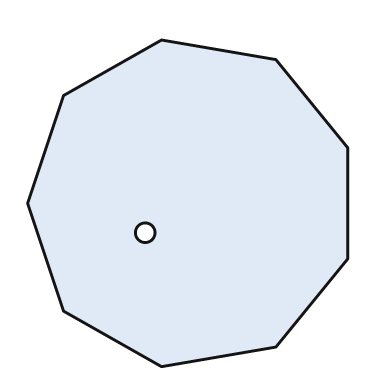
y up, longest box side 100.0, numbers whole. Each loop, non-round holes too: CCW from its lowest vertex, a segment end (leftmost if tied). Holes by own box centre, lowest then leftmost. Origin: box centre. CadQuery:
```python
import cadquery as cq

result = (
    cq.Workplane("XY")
    .moveTo(-8.0, -50.0)
    .lineTo(27.0, -44.0)
    .lineTo(49.0, -17.0)
    .lineTo(49.0, 17.0)
    .lineTo(27.0, 44.0)
    .lineTo(-8.0, 50.0)
    .lineTo(-38.0, 33.0)
    .lineTo(-49.0, 0.0)
    .lineTo(-38.0, -33.0)
    .close()
    .moveTo(-13.0, -9.0)
    .circle(3.0)
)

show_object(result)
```